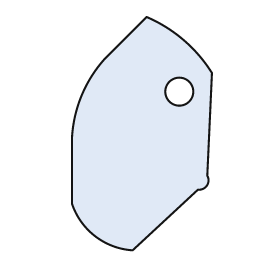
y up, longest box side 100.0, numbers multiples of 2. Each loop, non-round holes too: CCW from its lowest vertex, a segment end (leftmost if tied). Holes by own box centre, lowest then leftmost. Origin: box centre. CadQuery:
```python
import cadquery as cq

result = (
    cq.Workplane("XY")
    .moveTo(-4.0, -50.0)
    .lineTo(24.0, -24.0)
    .threePointArc((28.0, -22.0), (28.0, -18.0))
    .lineTo(30.0, 26.0)
    .threePointArc((18.0, 40.0), (2.0, 50.0))
    .lineTo(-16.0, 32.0)
    .threePointArc((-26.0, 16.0), (-30.0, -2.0))
    .lineTo(-30.0, -30.0)
    .threePointArc((-20.0, -44.0), (-4.0, -50.0))
    .close()
    .moveTo(16.0, 18.0)
    .circle(6.0)
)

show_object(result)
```